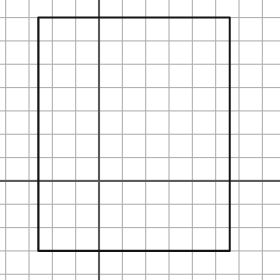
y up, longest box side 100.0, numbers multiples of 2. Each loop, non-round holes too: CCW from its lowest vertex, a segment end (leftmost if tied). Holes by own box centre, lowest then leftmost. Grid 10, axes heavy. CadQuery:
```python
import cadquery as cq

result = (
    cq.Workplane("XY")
    .moveTo(-26.0, -30.0)
    .lineTo(56.0, -30.0)
    .lineTo(56.0, 70.0)
    .lineTo(-26.0, 70.0)
    .close()
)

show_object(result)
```